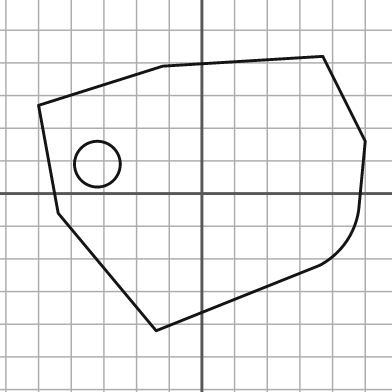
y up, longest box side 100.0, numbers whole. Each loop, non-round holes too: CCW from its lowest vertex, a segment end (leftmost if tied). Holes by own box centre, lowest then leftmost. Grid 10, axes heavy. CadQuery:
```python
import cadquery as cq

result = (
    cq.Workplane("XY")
    .moveTo(-14.0, -42.0)
    .lineTo(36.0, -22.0)
    .threePointArc((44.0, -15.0), (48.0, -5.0))
    .lineTo(50.0, 16.0)
    .lineTo(37.0, 42.0)
    .lineTo(-12.0, 39.0)
    .lineTo(-50.0, 27.0)
    .lineTo(-44.0, -6.0)
    .close()
    .moveTo(-32.0, 9.0)
    .circle(7.0)
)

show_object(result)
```